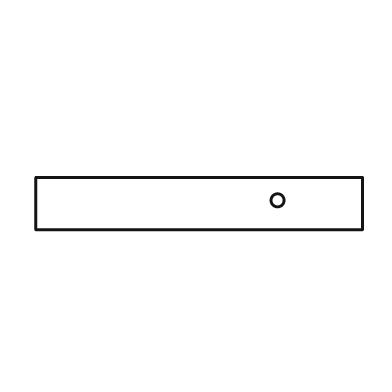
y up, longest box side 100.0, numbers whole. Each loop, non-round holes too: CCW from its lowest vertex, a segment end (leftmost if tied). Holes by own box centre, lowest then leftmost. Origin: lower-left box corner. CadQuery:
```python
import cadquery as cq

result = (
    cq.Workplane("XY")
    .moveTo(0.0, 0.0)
    .lineTo(100.0, 0.0)
    .lineTo(100.0, 16.0)
    .lineTo(0.0, 16.0)
    .close()
    .moveTo(74.0, 9.0)
    .circle(2.0)
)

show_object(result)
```